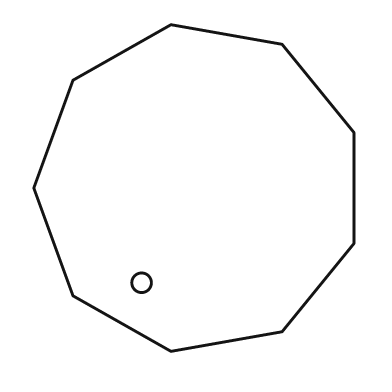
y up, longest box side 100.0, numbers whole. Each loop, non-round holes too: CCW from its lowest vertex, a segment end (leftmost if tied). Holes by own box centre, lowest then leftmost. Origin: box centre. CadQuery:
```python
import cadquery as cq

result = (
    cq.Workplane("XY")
    .moveTo(-7.0, -50.0)
    .lineTo(27.0, -44.0)
    .lineTo(49.0, -17.0)
    .lineTo(49.0, 17.0)
    .lineTo(27.0, 44.0)
    .lineTo(-7.0, 50.0)
    .lineTo(-37.0, 33.0)
    .lineTo(-49.0, 0.0)
    .lineTo(-37.0, -33.0)
    .close()
    .moveTo(-16.0, -29.0)
    .circle(3.0)
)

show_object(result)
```